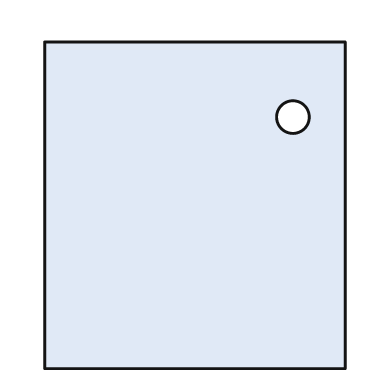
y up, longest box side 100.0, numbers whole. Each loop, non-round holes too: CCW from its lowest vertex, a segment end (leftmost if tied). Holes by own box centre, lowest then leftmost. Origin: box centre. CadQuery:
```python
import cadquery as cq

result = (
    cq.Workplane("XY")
    .moveTo(-46.0, -50.0)
    .lineTo(46.0, -50.0)
    .lineTo(46.0, 50.0)
    .lineTo(-46.0, 50.0)
    .close()
    .moveTo(30.0, 27.0)
    .circle(5.0)
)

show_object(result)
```